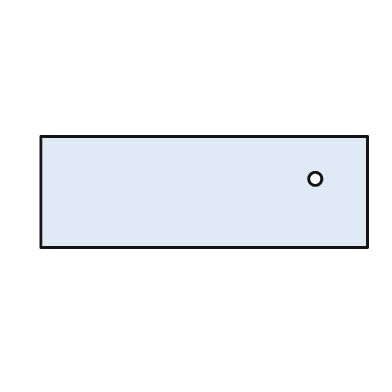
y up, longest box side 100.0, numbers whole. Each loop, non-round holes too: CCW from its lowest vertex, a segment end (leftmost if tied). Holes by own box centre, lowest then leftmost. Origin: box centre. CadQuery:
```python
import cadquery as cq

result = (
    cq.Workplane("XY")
    .moveTo(-50.0, -17.0)
    .lineTo(50.0, -17.0)
    .lineTo(50.0, 17.0)
    .lineTo(-50.0, 17.0)
    .close()
    .moveTo(34.0, 4.0)
    .circle(2.0)
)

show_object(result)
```